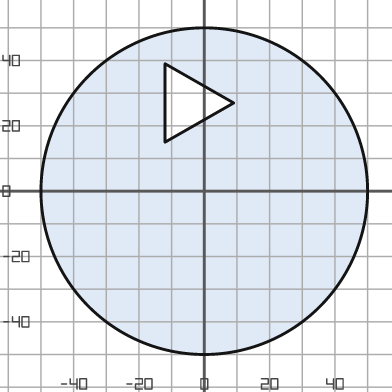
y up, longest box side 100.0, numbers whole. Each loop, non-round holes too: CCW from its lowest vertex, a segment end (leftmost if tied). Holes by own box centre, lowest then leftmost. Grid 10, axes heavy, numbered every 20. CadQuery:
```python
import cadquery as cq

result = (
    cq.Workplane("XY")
    .moveTo(0.0, 0.0)
    .circle(50.0)
    .moveTo(-12.0, 15.0)
    .lineTo(9.0, 27.0)
    .lineTo(-12.0, 39.0)
    .close()
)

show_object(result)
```